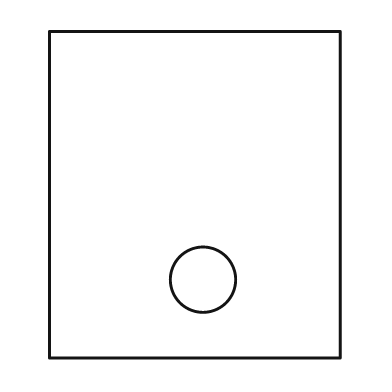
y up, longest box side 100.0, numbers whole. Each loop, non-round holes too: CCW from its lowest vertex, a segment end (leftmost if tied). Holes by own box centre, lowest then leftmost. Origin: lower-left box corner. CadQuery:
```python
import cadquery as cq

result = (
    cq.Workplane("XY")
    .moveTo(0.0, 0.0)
    .lineTo(89.0, 0.0)
    .lineTo(89.0, 100.0)
    .lineTo(0.0, 100.0)
    .close()
    .moveTo(47.0, 24.0)
    .circle(10.0)
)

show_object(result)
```